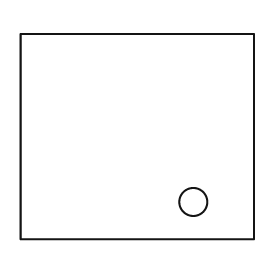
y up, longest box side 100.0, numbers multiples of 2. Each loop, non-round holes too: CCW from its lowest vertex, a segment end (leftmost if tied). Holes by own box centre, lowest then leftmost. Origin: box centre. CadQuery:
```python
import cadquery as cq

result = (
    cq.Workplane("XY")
    .moveTo(-50.0, -44.0)
    .lineTo(50.0, -44.0)
    .lineTo(50.0, 44.0)
    .lineTo(-50.0, 44.0)
    .close()
    .moveTo(24.0, -28.0)
    .circle(6.0)
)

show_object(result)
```